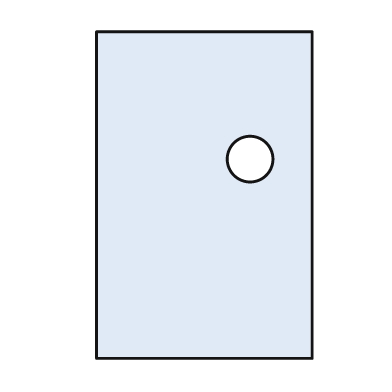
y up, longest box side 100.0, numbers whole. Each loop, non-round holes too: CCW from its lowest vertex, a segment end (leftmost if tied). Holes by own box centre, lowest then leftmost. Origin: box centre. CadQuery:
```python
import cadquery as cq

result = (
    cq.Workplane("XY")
    .moveTo(-33.0, -50.0)
    .lineTo(33.0, -50.0)
    .lineTo(33.0, 50.0)
    .lineTo(-33.0, 50.0)
    .close()
    .moveTo(14.0, 11.0)
    .circle(7.0)
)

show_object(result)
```